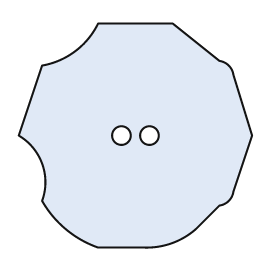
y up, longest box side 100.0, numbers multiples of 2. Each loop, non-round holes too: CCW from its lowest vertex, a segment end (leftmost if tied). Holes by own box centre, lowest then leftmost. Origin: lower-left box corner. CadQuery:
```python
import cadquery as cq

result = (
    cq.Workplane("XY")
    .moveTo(34.0, 0.0)
    .lineTo(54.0, 0.0)
    .threePointArc((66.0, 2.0), (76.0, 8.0))
    .lineTo(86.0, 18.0)
    .threePointArc((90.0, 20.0), (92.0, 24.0))
    .lineTo(100.0, 48.0)
    .lineTo(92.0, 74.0)
    .threePointArc((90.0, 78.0), (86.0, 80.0))
    .lineTo(66.0, 96.0)
    .lineTo(34.0, 96.0)
    .threePointArc((24.0, 84.0), (10.0, 78.0))
    .lineTo(0.0, 48.0)
    .threePointArc((10.0, 36.0), (10.0, 20.0))
    .threePointArc((20.0, 8.0), (34.0, 0.0))
    .close()
    .moveTo(44.0, 48.0)
    .circle(4.0)
    .moveTo(56.0, 48.0)
    .circle(4.0)
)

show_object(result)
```